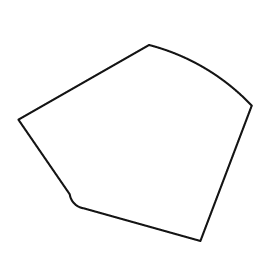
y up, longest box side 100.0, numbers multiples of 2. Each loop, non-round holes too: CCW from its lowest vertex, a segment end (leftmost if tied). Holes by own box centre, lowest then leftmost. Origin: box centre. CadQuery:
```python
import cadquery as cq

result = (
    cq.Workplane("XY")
    .moveTo(28.0, -42.0)
    .lineTo(50.0, 16.0)
    .threePointArc((30.0, 32.0), (6.0, 42.0))
    .lineTo(-50.0, 10.0)
    .lineTo(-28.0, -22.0)
    .threePointArc((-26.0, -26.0), (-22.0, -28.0))
    .close()
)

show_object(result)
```